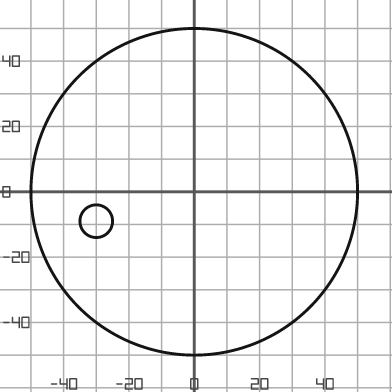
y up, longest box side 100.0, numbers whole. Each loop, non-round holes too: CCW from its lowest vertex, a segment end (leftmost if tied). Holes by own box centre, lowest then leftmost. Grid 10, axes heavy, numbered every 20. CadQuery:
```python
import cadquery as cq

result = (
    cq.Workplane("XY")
    .moveTo(0.0, 0.0)
    .circle(50.0)
    .moveTo(-30.0, -9.0)
    .circle(5.0)
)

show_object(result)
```